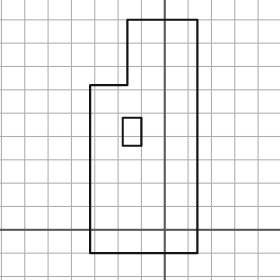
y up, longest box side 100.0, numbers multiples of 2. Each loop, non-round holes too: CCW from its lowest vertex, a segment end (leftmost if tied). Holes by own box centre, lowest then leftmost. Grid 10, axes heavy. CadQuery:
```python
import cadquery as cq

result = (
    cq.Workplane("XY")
    .moveTo(-32.0, -10.0)
    .lineTo(14.0, -10.0)
    .lineTo(14.0, 90.0)
    .lineTo(-16.0, 90.0)
    .lineTo(-16.0, 62.0)
    .lineTo(-32.0, 62.0)
    .close()
    .moveTo(-18.0, 36.0)
    .lineTo(-10.0, 36.0)
    .lineTo(-10.0, 48.0)
    .lineTo(-18.0, 48.0)
    .close()
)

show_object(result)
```